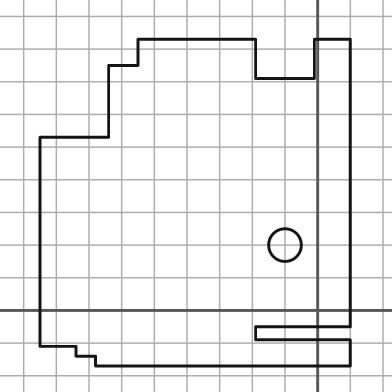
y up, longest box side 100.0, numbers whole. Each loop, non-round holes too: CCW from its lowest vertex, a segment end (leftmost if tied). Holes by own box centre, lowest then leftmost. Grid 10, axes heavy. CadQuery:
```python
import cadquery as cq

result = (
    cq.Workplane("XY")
    .moveTo(-68.0, -17.0)
    .lineTo(10.0, -17.0)
    .lineTo(10.0, -9.0)
    .lineTo(-19.0, -9.0)
    .lineTo(-19.0, -5.0)
    .lineTo(10.0, -5.0)
    .lineTo(10.0, 83.0)
    .lineTo(-1.0, 83.0)
    .lineTo(-1.0, 71.0)
    .lineTo(-19.0, 71.0)
    .lineTo(-19.0, 83.0)
    .lineTo(-55.0, 83.0)
    .lineTo(-55.0, 75.0)
    .lineTo(-64.0, 75.0)
    .lineTo(-64.0, 53.0)
    .lineTo(-85.0, 53.0)
    .lineTo(-85.0, -11.0)
    .lineTo(-74.0, -11.0)
    .lineTo(-74.0, -14.0)
    .lineTo(-68.0, -14.0)
    .close()
    .moveTo(-10.0, 20.0)
    .circle(5.0)
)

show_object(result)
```